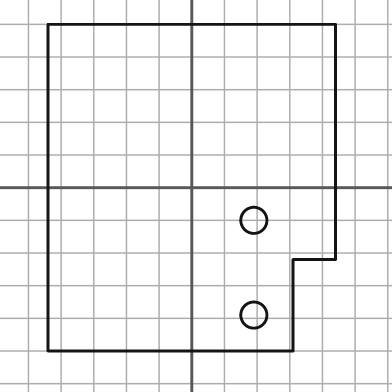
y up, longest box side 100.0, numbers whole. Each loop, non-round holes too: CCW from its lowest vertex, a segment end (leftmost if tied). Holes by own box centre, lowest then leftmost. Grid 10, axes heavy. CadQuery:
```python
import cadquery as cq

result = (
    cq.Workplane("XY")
    .moveTo(-44.0, -50.0)
    .lineTo(31.0, -50.0)
    .lineTo(31.0, -22.0)
    .lineTo(44.0, -22.0)
    .lineTo(44.0, 50.0)
    .lineTo(-44.0, 50.0)
    .close()
    .moveTo(19.0, -39.0)
    .circle(4.0)
    .moveTo(19.0, -10.0)
    .circle(4.0)
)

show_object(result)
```